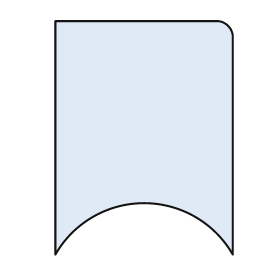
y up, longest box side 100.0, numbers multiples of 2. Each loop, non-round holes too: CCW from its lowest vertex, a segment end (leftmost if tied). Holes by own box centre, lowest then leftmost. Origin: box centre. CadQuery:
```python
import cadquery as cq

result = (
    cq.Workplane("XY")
    .moveTo(-38.0, -50.0)
    .threePointArc((0.0, -28.0), (38.0, -50.0))
    .lineTo(38.0, 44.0)
    .threePointArc((36.0, 48.0), (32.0, 50.0))
    .lineTo(-38.0, 50.0)
    .close()
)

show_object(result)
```